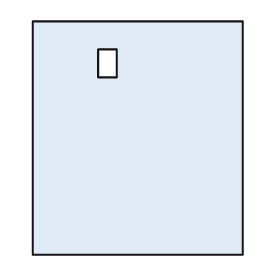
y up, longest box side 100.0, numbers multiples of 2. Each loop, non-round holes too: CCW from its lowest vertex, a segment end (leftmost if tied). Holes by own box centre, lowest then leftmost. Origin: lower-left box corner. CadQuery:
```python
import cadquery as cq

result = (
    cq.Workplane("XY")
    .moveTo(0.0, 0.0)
    .lineTo(90.0, 0.0)
    .lineTo(90.0, 100.0)
    .lineTo(0.0, 100.0)
    .close()
    .moveTo(28.0, 76.0)
    .lineTo(36.0, 76.0)
    .lineTo(36.0, 88.0)
    .lineTo(28.0, 88.0)
    .close()
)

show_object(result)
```